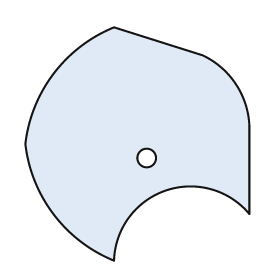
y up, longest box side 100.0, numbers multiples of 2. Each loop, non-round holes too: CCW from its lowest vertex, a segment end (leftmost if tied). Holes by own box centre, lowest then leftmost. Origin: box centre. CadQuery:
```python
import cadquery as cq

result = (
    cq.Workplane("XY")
    .moveTo(-10.0, -50.0)
    .threePointArc((12.0, -20.0), (48.0, -30.0))
    .lineTo(48.0, 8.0)
    .threePointArc((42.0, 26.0), (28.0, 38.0))
    .lineTo(-10.0, 50.0)
    .threePointArc((-36.0, 30.0), (-48.0, 0.0))
    .threePointArc((-36.0, -30.0), (-10.0, -50.0))
    .close()
    .moveTo(4.0, -6.0)
    .circle(4.0)
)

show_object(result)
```